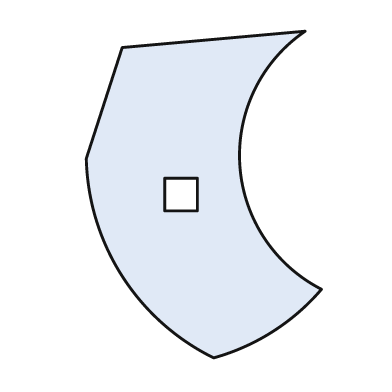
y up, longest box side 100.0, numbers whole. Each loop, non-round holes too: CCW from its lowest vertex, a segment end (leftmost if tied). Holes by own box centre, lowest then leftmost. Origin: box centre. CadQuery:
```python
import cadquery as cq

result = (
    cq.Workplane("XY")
    .moveTo(3.0, -50.0)
    .threePointArc((21.0, -42.0), (36.0, -29.0))
    .threePointArc((11.0, 9.0), (31.0, 50.0))
    .lineTo(-25.0, 45.0)
    .lineTo(-36.0, 11.0)
    .threePointArc((-25.0, -25.0), (3.0, -50.0))
    .close()
    .moveTo(-12.0, -5.0)
    .lineTo(-2.0, -5.0)
    .lineTo(-2.0, 5.0)
    .lineTo(-12.0, 5.0)
    .close()
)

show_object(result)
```